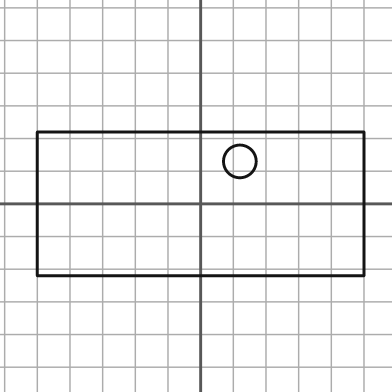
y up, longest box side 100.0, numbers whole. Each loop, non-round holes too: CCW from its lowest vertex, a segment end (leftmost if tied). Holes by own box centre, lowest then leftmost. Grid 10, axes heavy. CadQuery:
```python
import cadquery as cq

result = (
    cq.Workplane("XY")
    .moveTo(-50.0, -22.0)
    .lineTo(50.0, -22.0)
    .lineTo(50.0, 22.0)
    .lineTo(-50.0, 22.0)
    .close()
    .moveTo(12.0, 13.0)
    .circle(5.0)
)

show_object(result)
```